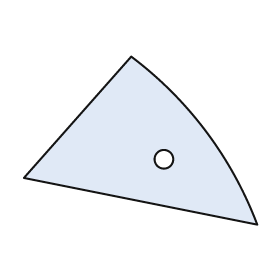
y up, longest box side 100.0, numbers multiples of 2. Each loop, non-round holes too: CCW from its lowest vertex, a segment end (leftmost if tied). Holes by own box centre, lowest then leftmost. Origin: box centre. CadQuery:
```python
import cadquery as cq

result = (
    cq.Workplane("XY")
    .moveTo(50.0, -36.0)
    .threePointArc((28.0, 4.0), (-4.0, 36.0))
    .lineTo(-50.0, -16.0)
    .close()
    .moveTo(10.0, -8.0)
    .circle(4.0)
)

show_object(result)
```